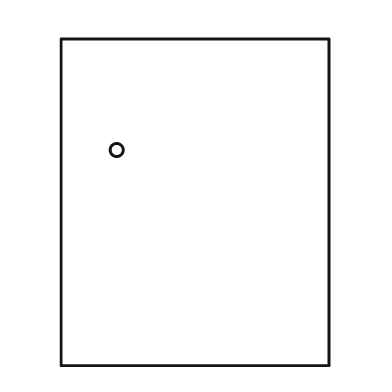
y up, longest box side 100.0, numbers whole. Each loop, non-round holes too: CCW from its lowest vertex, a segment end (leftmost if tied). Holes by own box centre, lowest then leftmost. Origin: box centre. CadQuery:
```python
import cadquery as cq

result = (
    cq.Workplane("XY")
    .moveTo(-41.0, -50.0)
    .lineTo(41.0, -50.0)
    .lineTo(41.0, 50.0)
    .lineTo(-41.0, 50.0)
    .close()
    .moveTo(-24.0, 16.0)
    .circle(2.0)
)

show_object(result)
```